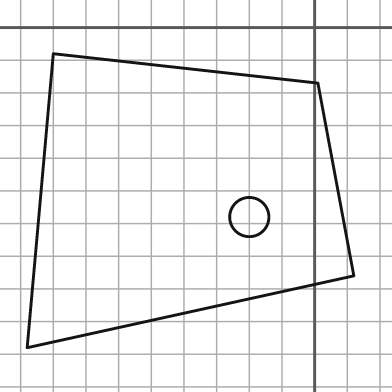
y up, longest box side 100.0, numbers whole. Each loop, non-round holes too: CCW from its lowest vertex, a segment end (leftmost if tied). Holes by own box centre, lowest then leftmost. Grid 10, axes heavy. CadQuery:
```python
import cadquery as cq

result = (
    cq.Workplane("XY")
    .moveTo(-88.0, -98.0)
    .lineTo(12.0, -76.0)
    .lineTo(1.0, -17.0)
    .lineTo(-80.0, -8.0)
    .close()
    .moveTo(-20.0, -58.0)
    .circle(6.0)
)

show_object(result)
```